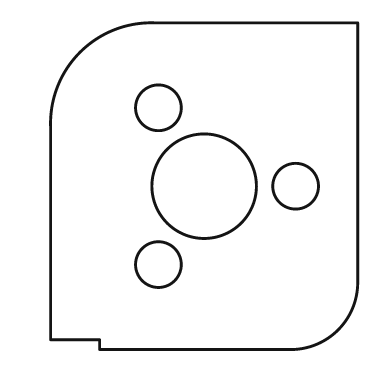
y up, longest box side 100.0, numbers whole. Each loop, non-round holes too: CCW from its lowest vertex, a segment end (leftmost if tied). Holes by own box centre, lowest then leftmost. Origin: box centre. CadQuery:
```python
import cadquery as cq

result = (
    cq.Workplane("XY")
    .moveTo(-32.0, -50.0)
    .lineTo(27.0, -50.0)
    .threePointArc((41.0, -44.0), (47.0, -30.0))
    .lineTo(47.0, 50.0)
    .lineTo(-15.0, 50.0)
    .threePointArc((-38.0, 41.0), (-47.0, 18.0))
    .lineTo(-47.0, -47.0)
    .lineTo(-32.0, -47.0)
    .close()
    .moveTo(-14.0, -24.0)
    .circle(7.0)
    .moveTo(0.0, 0.0)
    .circle(16.0)
    .moveTo(28.0, 0.0)
    .circle(7.0)
    .moveTo(-14.0, 24.0)
    .circle(7.0)
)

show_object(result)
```